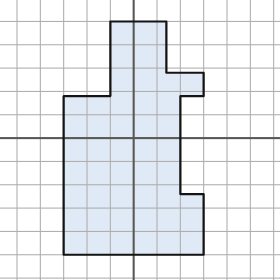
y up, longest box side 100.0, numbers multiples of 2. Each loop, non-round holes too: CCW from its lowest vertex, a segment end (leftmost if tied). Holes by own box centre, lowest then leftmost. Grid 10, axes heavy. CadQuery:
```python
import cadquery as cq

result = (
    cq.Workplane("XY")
    .moveTo(-30.0, -50.0)
    .lineTo(30.0, -50.0)
    .lineTo(30.0, -24.0)
    .lineTo(20.0, -24.0)
    .lineTo(20.0, 18.0)
    .lineTo(30.0, 18.0)
    .lineTo(30.0, 28.0)
    .lineTo(14.0, 28.0)
    .lineTo(14.0, 50.0)
    .lineTo(-10.0, 50.0)
    .lineTo(-10.0, 18.0)
    .lineTo(-30.0, 18.0)
    .close()
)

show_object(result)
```